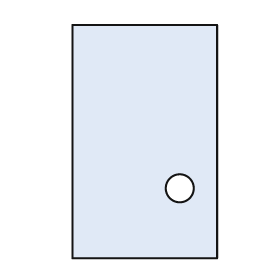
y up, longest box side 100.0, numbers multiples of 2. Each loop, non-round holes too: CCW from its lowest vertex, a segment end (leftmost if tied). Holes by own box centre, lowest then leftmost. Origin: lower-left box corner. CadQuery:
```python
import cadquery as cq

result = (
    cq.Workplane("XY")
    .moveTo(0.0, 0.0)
    .lineTo(62.0, 0.0)
    .lineTo(62.0, 100.0)
    .lineTo(0.0, 100.0)
    .close()
    .moveTo(46.0, 30.0)
    .circle(6.0)
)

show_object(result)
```